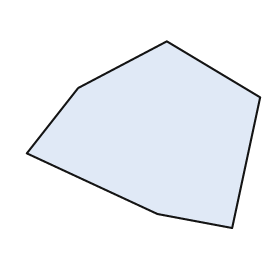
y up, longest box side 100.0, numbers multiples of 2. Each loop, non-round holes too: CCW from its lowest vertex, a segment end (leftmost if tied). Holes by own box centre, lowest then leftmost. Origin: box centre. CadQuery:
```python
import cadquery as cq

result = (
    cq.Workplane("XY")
    .moveTo(38.0, -40.0)
    .lineTo(50.0, 16.0)
    .lineTo(10.0, 40.0)
    .lineTo(-28.0, 20.0)
    .lineTo(-50.0, -8.0)
    .lineTo(6.0, -34.0)
    .close()
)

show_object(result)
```